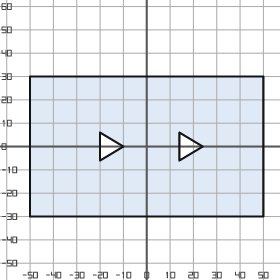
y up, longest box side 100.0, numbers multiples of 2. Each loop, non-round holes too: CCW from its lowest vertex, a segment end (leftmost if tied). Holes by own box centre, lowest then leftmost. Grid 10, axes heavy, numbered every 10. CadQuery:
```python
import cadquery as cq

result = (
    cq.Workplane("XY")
    .moveTo(-50.0, -30.0)
    .lineTo(50.0, -30.0)
    .lineTo(50.0, 30.0)
    .lineTo(-50.0, 30.0)
    .close()
    .moveTo(-20.0, -6.0)
    .lineTo(-10.0, 0.0)
    .lineTo(-20.0, 6.0)
    .close()
    .moveTo(14.0, -6.0)
    .lineTo(24.0, 0.0)
    .lineTo(14.0, 6.0)
    .close()
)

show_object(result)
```